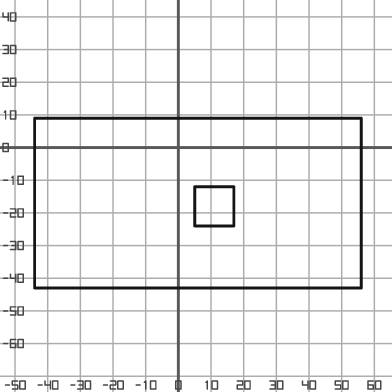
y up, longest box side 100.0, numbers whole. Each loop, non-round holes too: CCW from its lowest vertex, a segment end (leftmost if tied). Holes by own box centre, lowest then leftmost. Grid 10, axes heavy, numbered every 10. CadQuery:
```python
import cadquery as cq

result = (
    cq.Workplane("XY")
    .moveTo(-44.0, -43.0)
    .lineTo(56.0, -43.0)
    .lineTo(56.0, 9.0)
    .lineTo(-44.0, 9.0)
    .close()
    .moveTo(5.0, -24.0)
    .lineTo(17.0, -24.0)
    .lineTo(17.0, -12.0)
    .lineTo(5.0, -12.0)
    .close()
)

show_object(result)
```